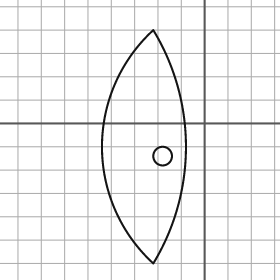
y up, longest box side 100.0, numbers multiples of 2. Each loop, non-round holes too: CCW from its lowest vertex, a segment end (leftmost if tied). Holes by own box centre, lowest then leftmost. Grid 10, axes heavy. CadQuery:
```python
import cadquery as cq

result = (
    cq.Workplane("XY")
    .moveTo(-22.0, -60.0)
    .threePointArc((-8.0, -10.0), (-22.0, 40.0))
    .threePointArc((-44.0, -10.0), (-22.0, -60.0))
    .close()
    .moveTo(-18.0, -14.0)
    .circle(4.0)
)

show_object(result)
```